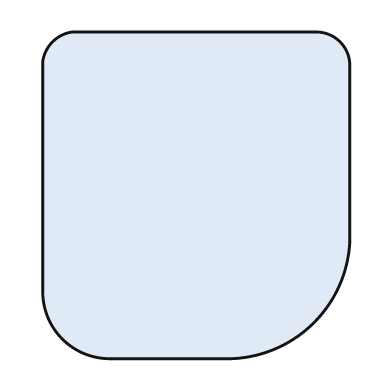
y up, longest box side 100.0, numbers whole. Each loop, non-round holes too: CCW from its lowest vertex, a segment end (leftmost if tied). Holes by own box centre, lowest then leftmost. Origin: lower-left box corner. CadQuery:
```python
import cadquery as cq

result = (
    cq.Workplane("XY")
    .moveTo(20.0, 0.0)
    .lineTo(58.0, 0.0)
    .threePointArc((83.0, 11.0), (94.0, 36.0))
    .lineTo(94.0, 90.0)
    .threePointArc((91.0, 97.0), (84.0, 100.0))
    .lineTo(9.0, 100.0)
    .threePointArc((3.0, 97.0), (0.0, 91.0))
    .lineTo(0.0, 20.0)
    .threePointArc((6.0, 6.0), (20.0, 0.0))
    .close()
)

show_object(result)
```